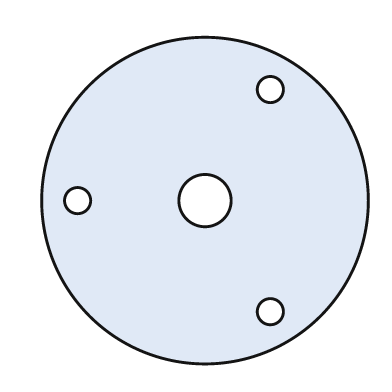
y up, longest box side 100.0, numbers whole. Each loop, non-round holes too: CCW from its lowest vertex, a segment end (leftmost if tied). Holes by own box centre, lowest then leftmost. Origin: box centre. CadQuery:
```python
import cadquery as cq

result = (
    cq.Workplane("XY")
    .moveTo(0.0, 0.0)
    .circle(50.0)
    .moveTo(20.0, -34.0)
    .circle(4.0)
    .moveTo(-39.0, 0.0)
    .circle(4.0)
    .moveTo(0.0, 0.0)
    .circle(8.0)
    .moveTo(20.0, 34.0)
    .circle(4.0)
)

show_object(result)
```